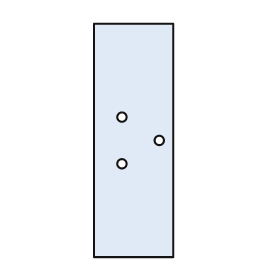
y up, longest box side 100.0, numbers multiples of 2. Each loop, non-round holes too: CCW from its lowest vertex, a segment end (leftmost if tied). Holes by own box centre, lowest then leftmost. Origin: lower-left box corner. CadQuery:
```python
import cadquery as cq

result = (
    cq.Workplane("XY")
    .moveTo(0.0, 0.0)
    .lineTo(34.0, 0.0)
    .lineTo(34.0, 100.0)
    .lineTo(0.0, 100.0)
    .close()
    .moveTo(12.0, 40.0)
    .circle(2.0)
    .moveTo(28.0, 50.0)
    .circle(2.0)
    .moveTo(12.0, 60.0)
    .circle(2.0)
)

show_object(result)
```